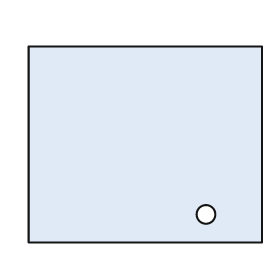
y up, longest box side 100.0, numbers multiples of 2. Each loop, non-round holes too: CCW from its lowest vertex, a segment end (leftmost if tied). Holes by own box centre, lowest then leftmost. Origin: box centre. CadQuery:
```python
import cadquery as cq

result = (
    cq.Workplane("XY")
    .moveTo(-50.0, -42.0)
    .lineTo(50.0, -42.0)
    .lineTo(50.0, 42.0)
    .lineTo(-50.0, 42.0)
    .close()
    .moveTo(26.0, -30.0)
    .circle(4.0)
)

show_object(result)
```